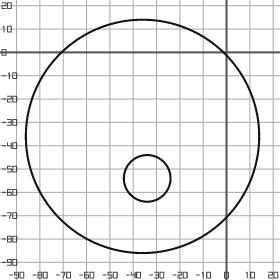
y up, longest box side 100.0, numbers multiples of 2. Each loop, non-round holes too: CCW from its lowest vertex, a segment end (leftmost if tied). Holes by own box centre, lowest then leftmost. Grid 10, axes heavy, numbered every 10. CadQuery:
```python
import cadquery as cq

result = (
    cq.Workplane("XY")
    .moveTo(-36.0, -36.0)
    .circle(50.0)
    .moveTo(-34.0, -54.0)
    .circle(10.0)
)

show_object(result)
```